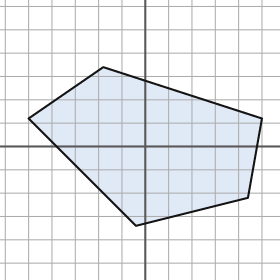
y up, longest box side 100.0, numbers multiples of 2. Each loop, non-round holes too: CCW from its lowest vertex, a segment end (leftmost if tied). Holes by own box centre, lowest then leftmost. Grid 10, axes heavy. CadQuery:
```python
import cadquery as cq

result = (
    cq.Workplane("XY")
    .moveTo(-4.0, -34.0)
    .lineTo(44.0, -22.0)
    .lineTo(50.0, 12.0)
    .lineTo(-18.0, 34.0)
    .lineTo(-50.0, 12.0)
    .close()
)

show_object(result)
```